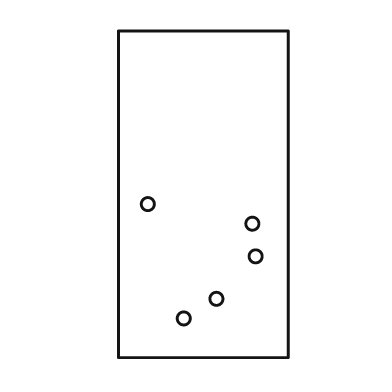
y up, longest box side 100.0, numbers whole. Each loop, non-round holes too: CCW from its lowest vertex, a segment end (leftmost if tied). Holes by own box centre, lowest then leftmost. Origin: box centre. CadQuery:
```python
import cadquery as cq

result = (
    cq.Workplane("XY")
    .moveTo(-26.0, -50.0)
    .lineTo(26.0, -50.0)
    .lineTo(26.0, 50.0)
    .lineTo(-26.0, 50.0)
    .close()
    .moveTo(-6.0, -38.0)
    .circle(2.0)
    .moveTo(4.0, -32.0)
    .circle(2.0)
    .moveTo(16.0, -19.0)
    .circle(2.0)
    .moveTo(15.0, -9.0)
    .circle(2.0)
    .moveTo(-17.0, -3.0)
    .circle(2.0)
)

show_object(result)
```